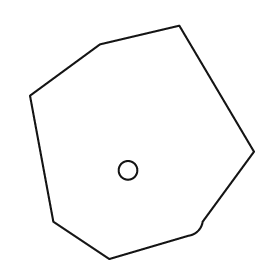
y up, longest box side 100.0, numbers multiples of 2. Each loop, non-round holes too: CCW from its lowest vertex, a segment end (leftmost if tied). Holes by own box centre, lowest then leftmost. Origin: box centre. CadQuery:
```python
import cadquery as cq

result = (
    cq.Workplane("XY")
    .moveTo(-14.0, -50.0)
    .lineTo(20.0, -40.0)
    .threePointArc((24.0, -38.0), (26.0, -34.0))
    .lineTo(48.0, -4.0)
    .lineTo(16.0, 50.0)
    .lineTo(-18.0, 42.0)
    .lineTo(-48.0, 20.0)
    .lineTo(-38.0, -34.0)
    .close()
    .moveTo(-6.0, -12.0)
    .circle(4.0)
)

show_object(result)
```